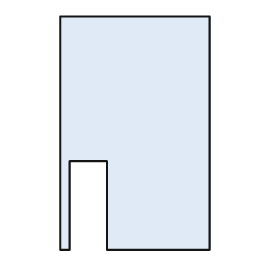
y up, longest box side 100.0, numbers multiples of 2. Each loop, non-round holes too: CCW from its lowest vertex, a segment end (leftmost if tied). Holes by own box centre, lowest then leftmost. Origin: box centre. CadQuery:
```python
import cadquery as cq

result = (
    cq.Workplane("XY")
    .moveTo(-32.0, -50.0)
    .lineTo(-28.0, -50.0)
    .lineTo(-28.0, -12.0)
    .lineTo(-12.0, -12.0)
    .lineTo(-12.0, -50.0)
    .lineTo(32.0, -50.0)
    .lineTo(32.0, 50.0)
    .lineTo(-32.0, 50.0)
    .close()
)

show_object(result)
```